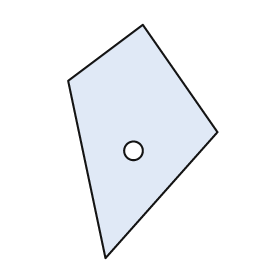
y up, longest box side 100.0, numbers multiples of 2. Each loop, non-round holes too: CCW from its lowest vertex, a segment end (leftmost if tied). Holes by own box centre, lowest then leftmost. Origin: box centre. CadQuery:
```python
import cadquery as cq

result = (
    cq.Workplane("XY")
    .moveTo(-16.0, -50.0)
    .lineTo(32.0, 4.0)
    .lineTo(0.0, 50.0)
    .lineTo(-32.0, 26.0)
    .close()
    .moveTo(-4.0, -4.0)
    .circle(4.0)
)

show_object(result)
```